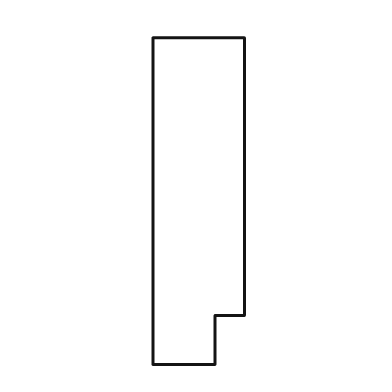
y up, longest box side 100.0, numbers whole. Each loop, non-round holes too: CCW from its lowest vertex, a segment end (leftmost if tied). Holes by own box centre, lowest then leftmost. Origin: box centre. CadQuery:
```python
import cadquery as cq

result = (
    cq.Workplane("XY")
    .moveTo(-14.0, -50.0)
    .lineTo(5.0, -50.0)
    .lineTo(5.0, -35.0)
    .lineTo(14.0, -35.0)
    .lineTo(14.0, 50.0)
    .lineTo(-14.0, 50.0)
    .close()
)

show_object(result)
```